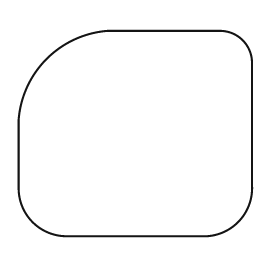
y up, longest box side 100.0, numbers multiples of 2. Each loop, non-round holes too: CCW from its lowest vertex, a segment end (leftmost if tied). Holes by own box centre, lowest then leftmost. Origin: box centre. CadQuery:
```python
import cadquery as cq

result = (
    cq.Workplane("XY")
    .moveTo(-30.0, -44.0)
    .lineTo(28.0, -44.0)
    .threePointArc((44.0, -38.0), (50.0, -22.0))
    .lineTo(50.0, 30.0)
    .threePointArc((46.0, 40.0), (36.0, 44.0))
    .lineTo(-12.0, 44.0)
    .threePointArc((-38.0, 32.0), (-50.0, 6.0))
    .lineTo(-50.0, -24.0)
    .threePointArc((-44.0, -38.0), (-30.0, -44.0))
    .close()
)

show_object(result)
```